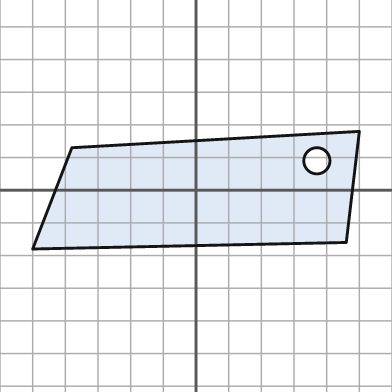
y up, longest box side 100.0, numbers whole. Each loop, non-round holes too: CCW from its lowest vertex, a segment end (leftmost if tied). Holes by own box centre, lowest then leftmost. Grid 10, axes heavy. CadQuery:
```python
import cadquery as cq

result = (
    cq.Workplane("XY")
    .moveTo(-50.0, -18.0)
    .lineTo(46.0, -16.0)
    .lineTo(50.0, 18.0)
    .lineTo(-38.0, 13.0)
    .close()
    .moveTo(37.0, 9.0)
    .circle(4.0)
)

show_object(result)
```